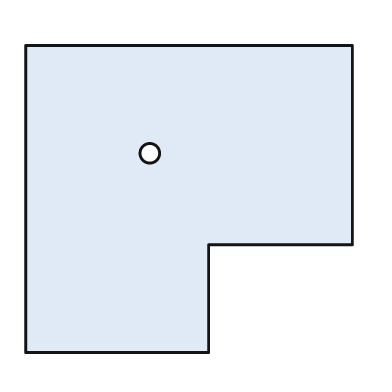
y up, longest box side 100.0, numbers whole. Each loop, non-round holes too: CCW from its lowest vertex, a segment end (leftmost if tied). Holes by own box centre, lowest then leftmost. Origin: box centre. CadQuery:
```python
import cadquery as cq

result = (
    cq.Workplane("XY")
    .moveTo(-50.0, -47.0)
    .lineTo(6.0, -47.0)
    .lineTo(6.0, -14.0)
    .lineTo(50.0, -14.0)
    .lineTo(50.0, 47.0)
    .lineTo(-50.0, 47.0)
    .close()
    .moveTo(-12.0, 14.0)
    .circle(3.0)
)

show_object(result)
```